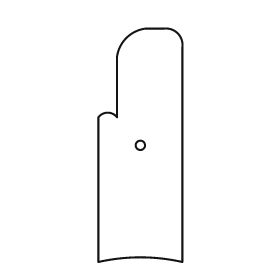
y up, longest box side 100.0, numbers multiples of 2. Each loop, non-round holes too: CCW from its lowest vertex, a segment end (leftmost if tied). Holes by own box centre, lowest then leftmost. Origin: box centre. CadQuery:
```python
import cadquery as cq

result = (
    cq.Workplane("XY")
    .moveTo(-18.0, -50.0)
    .threePointArc((0.0, -48.0), (18.0, -50.0))
    .lineTo(18.0, 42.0)
    .threePointArc((16.0, 48.0), (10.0, 50.0))
    .lineTo(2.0, 50.0)
    .threePointArc((-6.0, 46.0), (-10.0, 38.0))
    .lineTo(-10.0, 12.0)
    .threePointArc((-14.0, 14.0), (-18.0, 12.0))
    .close()
    .moveTo(0.0, 0.0)
    .circle(2.0)
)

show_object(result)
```